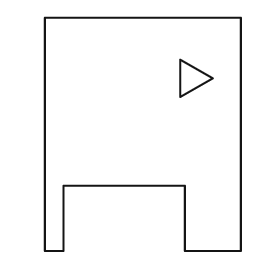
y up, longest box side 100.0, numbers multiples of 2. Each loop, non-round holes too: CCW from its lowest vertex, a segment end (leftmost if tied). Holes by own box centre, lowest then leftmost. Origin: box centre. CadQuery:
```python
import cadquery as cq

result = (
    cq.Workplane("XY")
    .moveTo(-42.0, -50.0)
    .lineTo(-34.0, -50.0)
    .lineTo(-34.0, -22.0)
    .lineTo(18.0, -22.0)
    .lineTo(18.0, -50.0)
    .lineTo(42.0, -50.0)
    .lineTo(42.0, 50.0)
    .lineTo(-42.0, 50.0)
    .close()
    .moveTo(16.0, 16.0)
    .lineTo(30.0, 24.0)
    .lineTo(16.0, 32.0)
    .close()
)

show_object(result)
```